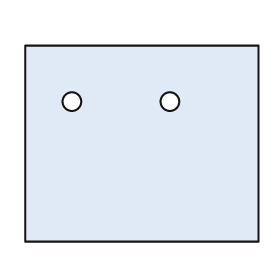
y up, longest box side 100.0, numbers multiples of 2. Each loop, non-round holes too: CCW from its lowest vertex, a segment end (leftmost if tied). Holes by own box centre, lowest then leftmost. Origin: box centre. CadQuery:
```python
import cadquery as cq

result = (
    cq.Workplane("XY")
    .moveTo(-50.0, -42.0)
    .lineTo(50.0, -42.0)
    .lineTo(50.0, 42.0)
    .lineTo(-50.0, 42.0)
    .close()
    .moveTo(-30.0, 18.0)
    .circle(4.0)
    .moveTo(12.0, 18.0)
    .circle(4.0)
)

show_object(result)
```